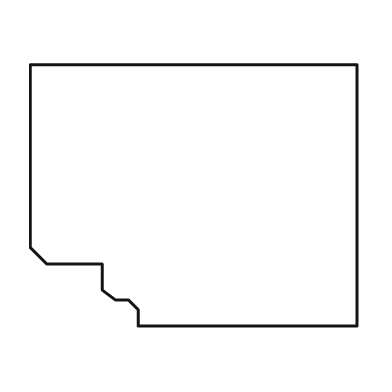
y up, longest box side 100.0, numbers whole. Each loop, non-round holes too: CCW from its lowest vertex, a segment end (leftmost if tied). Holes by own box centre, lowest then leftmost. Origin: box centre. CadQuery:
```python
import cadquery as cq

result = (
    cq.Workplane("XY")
    .moveTo(-17.0, -40.0)
    .lineTo(50.0, -40.0)
    .lineTo(50.0, 40.0)
    .lineTo(-50.0, 40.0)
    .lineTo(-50.0, -16.0)
    .lineTo(-45.0, -21.0)
    .lineTo(-28.0, -21.0)
    .lineTo(-28.0, -29.0)
    .lineTo(-24.0, -32.0)
    .lineTo(-20.0, -32.0)
    .lineTo(-17.0, -35.0)
    .close()
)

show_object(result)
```